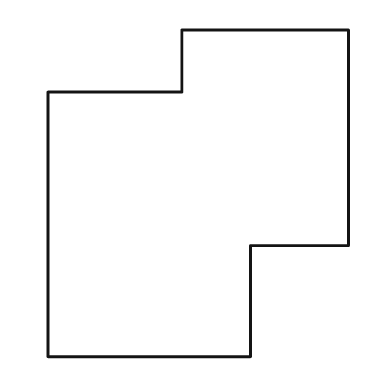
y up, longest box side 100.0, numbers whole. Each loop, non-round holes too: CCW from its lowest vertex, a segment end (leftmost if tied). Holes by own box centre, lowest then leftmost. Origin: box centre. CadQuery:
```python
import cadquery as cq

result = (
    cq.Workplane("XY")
    .moveTo(-46.0, -50.0)
    .lineTo(16.0, -50.0)
    .lineTo(16.0, -16.0)
    .lineTo(46.0, -16.0)
    .lineTo(46.0, 50.0)
    .lineTo(-5.0, 50.0)
    .lineTo(-5.0, 31.0)
    .lineTo(-46.0, 31.0)
    .close()
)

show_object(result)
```